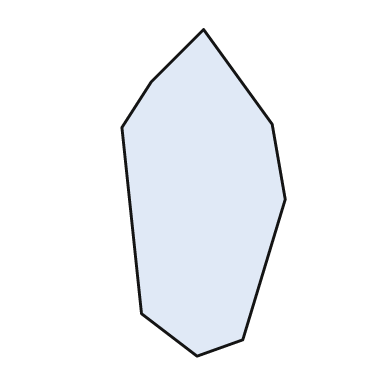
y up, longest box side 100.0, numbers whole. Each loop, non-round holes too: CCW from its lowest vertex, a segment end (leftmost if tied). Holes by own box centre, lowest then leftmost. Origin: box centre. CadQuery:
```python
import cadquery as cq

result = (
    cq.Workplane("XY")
    .moveTo(-2.0, -50.0)
    .lineTo(12.0, -45.0)
    .lineTo(25.0, -2.0)
    .lineTo(21.0, 21.0)
    .lineTo(0.0, 50.0)
    .lineTo(-16.0, 34.0)
    .lineTo(-25.0, 20.0)
    .lineTo(-19.0, -37.0)
    .close()
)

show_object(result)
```